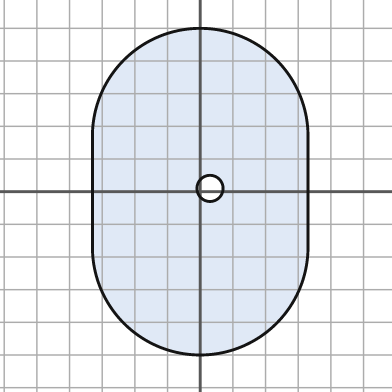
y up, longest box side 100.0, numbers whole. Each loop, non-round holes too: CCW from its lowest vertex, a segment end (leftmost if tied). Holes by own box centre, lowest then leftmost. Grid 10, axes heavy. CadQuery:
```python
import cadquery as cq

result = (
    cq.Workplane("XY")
    .moveTo(-33.0, -17.0)
    .threePointArc((0.0, -50.0), (33.0, -17.0))
    .lineTo(33.0, 17.0)
    .threePointArc((0.0, 50.0), (-33.0, 17.0))
    .close()
    .moveTo(3.0, 1.0)
    .circle(4.0)
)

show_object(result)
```